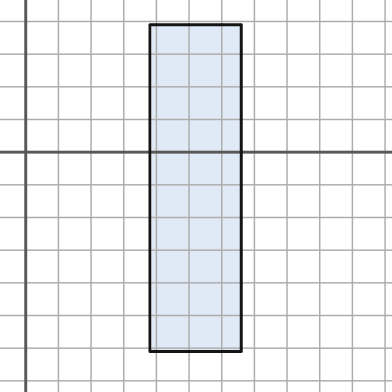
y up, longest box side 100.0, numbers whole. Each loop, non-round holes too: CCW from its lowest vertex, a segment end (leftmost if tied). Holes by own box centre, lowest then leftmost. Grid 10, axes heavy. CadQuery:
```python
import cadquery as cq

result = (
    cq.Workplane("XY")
    .moveTo(38.0, -61.0)
    .lineTo(66.0, -61.0)
    .lineTo(66.0, 39.0)
    .lineTo(38.0, 39.0)
    .close()
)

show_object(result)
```